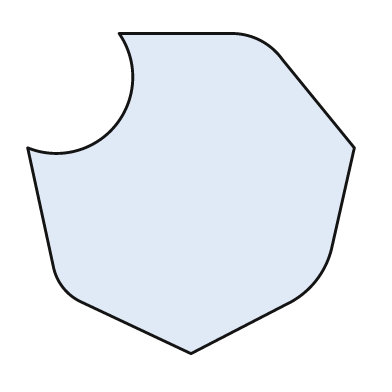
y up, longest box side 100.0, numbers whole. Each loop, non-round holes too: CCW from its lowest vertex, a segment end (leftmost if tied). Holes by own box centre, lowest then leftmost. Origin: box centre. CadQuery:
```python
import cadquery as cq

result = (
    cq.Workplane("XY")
    .moveTo(0.0, -49.0)
    .lineTo(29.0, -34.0)
    .threePointArc((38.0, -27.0), (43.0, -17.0))
    .lineTo(50.0, 14.0)
    .lineTo(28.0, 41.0)
    .threePointArc((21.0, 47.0), (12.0, 49.0))
    .lineTo(-22.0, 49.0)
    .threePointArc((-23.0, 21.0), (-50.0, 14.0))
    .lineTo(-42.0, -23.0)
    .threePointArc((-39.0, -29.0), (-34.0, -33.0))
    .close()
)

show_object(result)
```